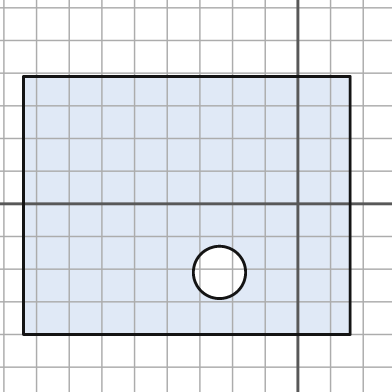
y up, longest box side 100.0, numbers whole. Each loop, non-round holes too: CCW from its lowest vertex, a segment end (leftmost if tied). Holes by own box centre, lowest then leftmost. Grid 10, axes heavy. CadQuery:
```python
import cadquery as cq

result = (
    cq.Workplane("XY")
    .moveTo(-84.0, -40.0)
    .lineTo(16.0, -40.0)
    .lineTo(16.0, 39.0)
    .lineTo(-84.0, 39.0)
    .close()
    .moveTo(-24.0, -21.0)
    .circle(8.0)
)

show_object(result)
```